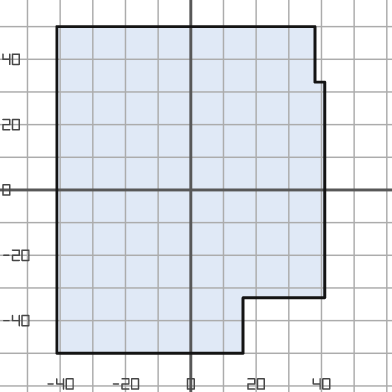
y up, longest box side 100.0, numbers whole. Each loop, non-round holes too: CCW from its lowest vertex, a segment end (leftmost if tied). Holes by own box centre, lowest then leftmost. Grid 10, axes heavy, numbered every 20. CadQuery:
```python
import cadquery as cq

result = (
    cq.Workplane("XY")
    .moveTo(-41.0, -50.0)
    .lineTo(16.0, -50.0)
    .lineTo(16.0, -33.0)
    .lineTo(41.0, -33.0)
    .lineTo(41.0, 33.0)
    .lineTo(38.0, 33.0)
    .lineTo(38.0, 50.0)
    .lineTo(-41.0, 50.0)
    .close()
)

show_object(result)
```